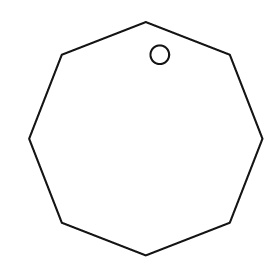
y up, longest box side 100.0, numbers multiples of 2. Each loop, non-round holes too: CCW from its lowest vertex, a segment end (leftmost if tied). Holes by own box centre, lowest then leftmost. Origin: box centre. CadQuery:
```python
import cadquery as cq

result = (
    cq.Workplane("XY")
    .moveTo(0.0, -50.0)
    .lineTo(36.0, -36.0)
    .lineTo(50.0, 0.0)
    .lineTo(36.0, 36.0)
    .lineTo(0.0, 50.0)
    .lineTo(-36.0, 36.0)
    .lineTo(-50.0, 0.0)
    .lineTo(-36.0, -36.0)
    .close()
    .moveTo(6.0, 36.0)
    .circle(4.0)
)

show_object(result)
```